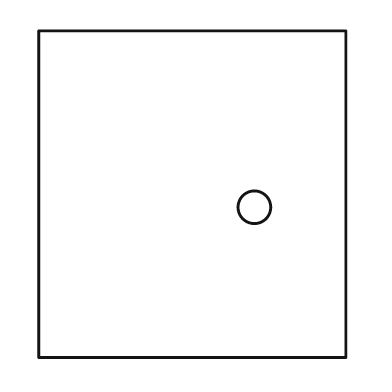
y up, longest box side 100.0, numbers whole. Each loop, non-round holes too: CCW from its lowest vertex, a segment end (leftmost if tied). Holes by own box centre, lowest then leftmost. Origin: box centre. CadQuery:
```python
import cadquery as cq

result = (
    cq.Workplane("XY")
    .moveTo(-47.0, -50.0)
    .lineTo(47.0, -50.0)
    .lineTo(47.0, 50.0)
    .lineTo(-47.0, 50.0)
    .close()
    .moveTo(19.0, -4.0)
    .circle(5.0)
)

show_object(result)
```